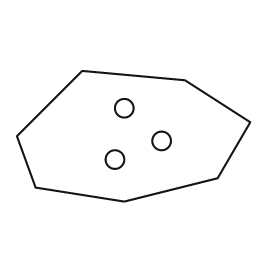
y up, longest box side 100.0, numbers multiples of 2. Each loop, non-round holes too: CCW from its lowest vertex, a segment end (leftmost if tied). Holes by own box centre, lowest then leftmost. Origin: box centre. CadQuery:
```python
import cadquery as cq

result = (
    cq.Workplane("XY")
    .moveTo(-4.0, -28.0)
    .lineTo(36.0, -18.0)
    .lineTo(50.0, 6.0)
    .lineTo(22.0, 24.0)
    .lineTo(-22.0, 28.0)
    .lineTo(-50.0, 0.0)
    .lineTo(-42.0, -22.0)
    .close()
    .moveTo(-8.0, -10.0)
    .circle(4.0)
    .moveTo(12.0, -2.0)
    .circle(4.0)
    .moveTo(-4.0, 12.0)
    .circle(4.0)
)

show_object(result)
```